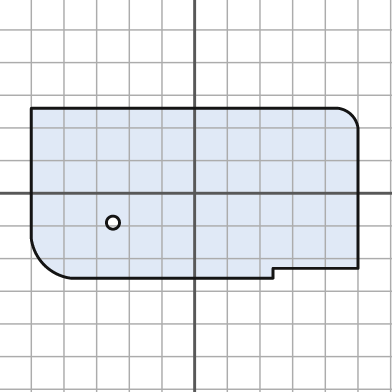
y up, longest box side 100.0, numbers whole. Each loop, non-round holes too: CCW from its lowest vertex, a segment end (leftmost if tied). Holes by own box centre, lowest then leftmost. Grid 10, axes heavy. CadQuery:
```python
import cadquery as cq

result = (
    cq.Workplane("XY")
    .moveTo(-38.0, -26.0)
    .lineTo(24.0, -26.0)
    .lineTo(24.0, -23.0)
    .lineTo(50.0, -23.0)
    .lineTo(50.0, 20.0)
    .threePointArc((48.0, 24.0), (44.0, 26.0))
    .lineTo(-50.0, 26.0)
    .lineTo(-50.0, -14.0)
    .threePointArc((-46.0, -22.0), (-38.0, -26.0))
    .close()
    .moveTo(-25.0, -9.0)
    .circle(2.0)
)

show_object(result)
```